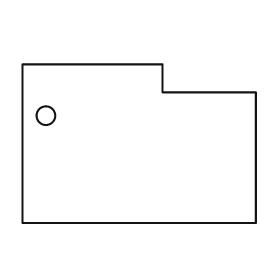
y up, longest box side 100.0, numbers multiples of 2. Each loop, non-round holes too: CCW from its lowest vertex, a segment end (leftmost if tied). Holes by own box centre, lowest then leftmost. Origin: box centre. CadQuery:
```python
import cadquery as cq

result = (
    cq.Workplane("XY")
    .moveTo(-50.0, -34.0)
    .lineTo(50.0, -34.0)
    .lineTo(50.0, 22.0)
    .lineTo(10.0, 22.0)
    .lineTo(10.0, 34.0)
    .lineTo(-50.0, 34.0)
    .close()
    .moveTo(-40.0, 12.0)
    .circle(4.0)
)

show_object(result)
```